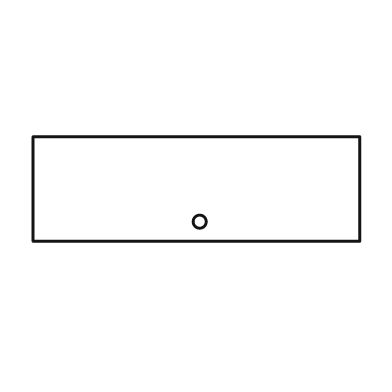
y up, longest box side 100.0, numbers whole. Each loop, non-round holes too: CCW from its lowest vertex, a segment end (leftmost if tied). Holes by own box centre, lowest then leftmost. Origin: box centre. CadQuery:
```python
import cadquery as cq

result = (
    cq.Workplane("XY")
    .moveTo(-50.0, -16.0)
    .lineTo(50.0, -16.0)
    .lineTo(50.0, 16.0)
    .lineTo(-50.0, 16.0)
    .close()
    .moveTo(1.0, -10.0)
    .circle(2.0)
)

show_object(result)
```